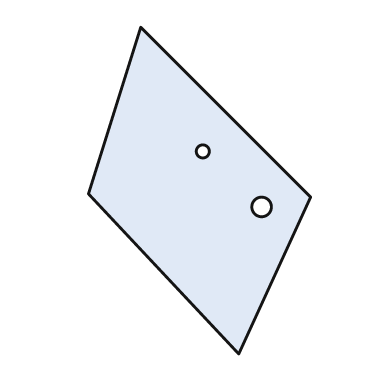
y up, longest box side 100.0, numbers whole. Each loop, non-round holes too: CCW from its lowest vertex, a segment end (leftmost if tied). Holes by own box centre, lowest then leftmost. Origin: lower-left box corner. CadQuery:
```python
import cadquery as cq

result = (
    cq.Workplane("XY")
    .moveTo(46.0, 0.0)
    .lineTo(68.0, 48.0)
    .lineTo(16.0, 100.0)
    .lineTo(0.0, 49.0)
    .close()
    .moveTo(53.0, 45.0)
    .circle(3.0)
    .moveTo(35.0, 62.0)
    .circle(2.0)
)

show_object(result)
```